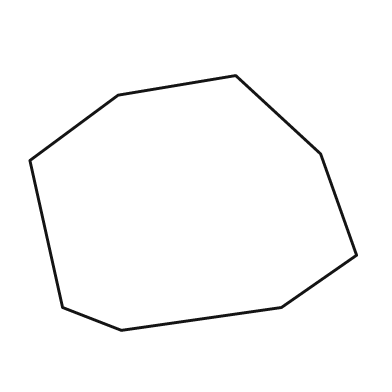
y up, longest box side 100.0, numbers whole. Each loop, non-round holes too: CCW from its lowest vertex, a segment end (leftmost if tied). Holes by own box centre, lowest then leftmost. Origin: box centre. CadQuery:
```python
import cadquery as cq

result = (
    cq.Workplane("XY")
    .moveTo(-22.0, -39.0)
    .lineTo(27.0, -32.0)
    .lineTo(50.0, -16.0)
    .lineTo(39.0, 15.0)
    .lineTo(13.0, 39.0)
    .lineTo(-23.0, 33.0)
    .lineTo(-50.0, 13.0)
    .lineTo(-40.0, -32.0)
    .close()
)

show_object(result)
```